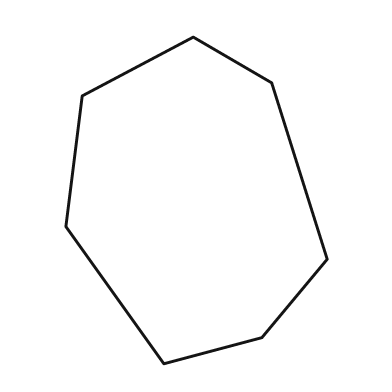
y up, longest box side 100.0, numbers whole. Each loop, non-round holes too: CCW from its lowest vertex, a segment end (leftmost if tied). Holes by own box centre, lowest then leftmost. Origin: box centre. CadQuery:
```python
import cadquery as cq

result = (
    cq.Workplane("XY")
    .moveTo(-10.0, -50.0)
    .lineTo(20.0, -42.0)
    .lineTo(40.0, -18.0)
    .lineTo(23.0, 36.0)
    .lineTo(-1.0, 50.0)
    .lineTo(-35.0, 32.0)
    .lineTo(-40.0, -8.0)
    .close()
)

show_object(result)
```